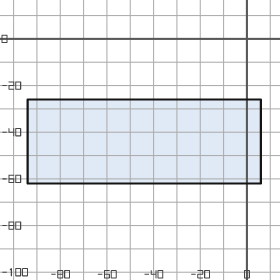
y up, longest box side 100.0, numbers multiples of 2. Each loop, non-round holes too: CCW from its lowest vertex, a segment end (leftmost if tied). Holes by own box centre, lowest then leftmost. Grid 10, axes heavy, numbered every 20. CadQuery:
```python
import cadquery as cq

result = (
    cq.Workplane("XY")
    .moveTo(-94.0, -62.0)
    .lineTo(6.0, -62.0)
    .lineTo(6.0, -26.0)
    .lineTo(-94.0, -26.0)
    .close()
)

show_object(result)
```